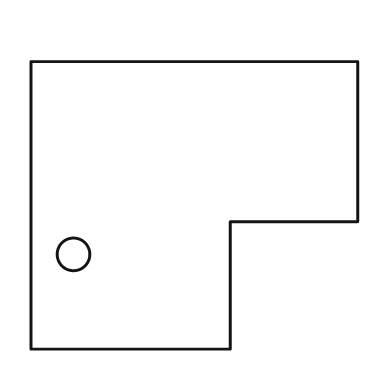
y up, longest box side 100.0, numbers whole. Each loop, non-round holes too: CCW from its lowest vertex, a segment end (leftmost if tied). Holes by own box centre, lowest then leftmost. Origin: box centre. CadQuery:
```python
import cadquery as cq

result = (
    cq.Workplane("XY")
    .moveTo(-50.0, -44.0)
    .lineTo(11.0, -44.0)
    .lineTo(11.0, -5.0)
    .lineTo(50.0, -5.0)
    .lineTo(50.0, 44.0)
    .lineTo(-50.0, 44.0)
    .close()
    .moveTo(-37.0, -15.0)
    .circle(5.0)
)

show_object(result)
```